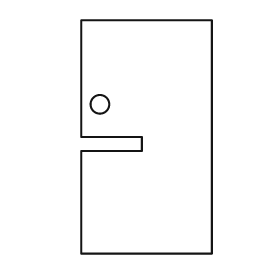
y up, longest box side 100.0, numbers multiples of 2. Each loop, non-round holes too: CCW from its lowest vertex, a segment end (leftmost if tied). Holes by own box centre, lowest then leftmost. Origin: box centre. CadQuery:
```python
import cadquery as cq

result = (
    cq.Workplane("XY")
    .moveTo(-28.0, -50.0)
    .lineTo(28.0, -50.0)
    .lineTo(28.0, 50.0)
    .lineTo(-28.0, 50.0)
    .lineTo(-28.0, 0.0)
    .lineTo(-2.0, 0.0)
    .lineTo(-2.0, -6.0)
    .lineTo(-28.0, -6.0)
    .close()
    .moveTo(-20.0, 14.0)
    .circle(4.0)
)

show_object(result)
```